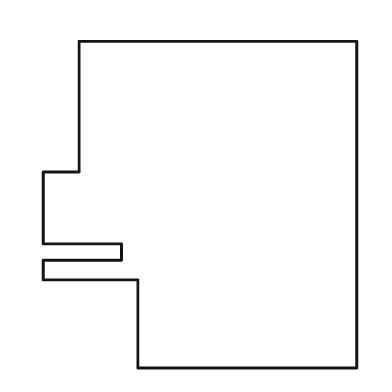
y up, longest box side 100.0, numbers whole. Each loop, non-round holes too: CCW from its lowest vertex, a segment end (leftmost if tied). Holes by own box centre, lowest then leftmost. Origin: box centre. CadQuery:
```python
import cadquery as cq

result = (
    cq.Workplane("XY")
    .moveTo(-19.0, -50.0)
    .lineTo(48.0, -50.0)
    .lineTo(48.0, 50.0)
    .lineTo(-37.0, 50.0)
    .lineTo(-37.0, 10.0)
    .lineTo(-48.0, 10.0)
    .lineTo(-48.0, -12.0)
    .lineTo(-24.0, -12.0)
    .lineTo(-24.0, -17.0)
    .lineTo(-48.0, -17.0)
    .lineTo(-48.0, -23.0)
    .lineTo(-19.0, -23.0)
    .close()
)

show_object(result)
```